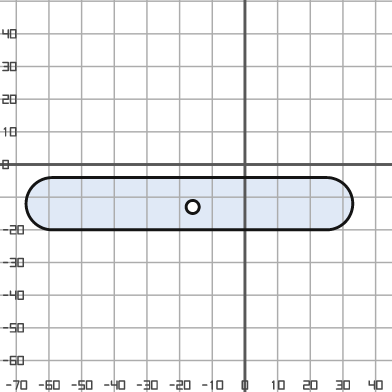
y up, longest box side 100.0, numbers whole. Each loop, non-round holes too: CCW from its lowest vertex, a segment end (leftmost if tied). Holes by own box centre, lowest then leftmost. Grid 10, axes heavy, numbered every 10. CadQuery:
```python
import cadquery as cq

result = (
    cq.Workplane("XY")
    .moveTo(-59.0, -20.0)
    .lineTo(25.0, -20.0)
    .threePointArc((33.0, -12.0), (25.0, -4.0))
    .lineTo(-59.0, -4.0)
    .threePointArc((-67.0, -12.0), (-59.0, -20.0))
    .close()
    .moveTo(-16.0, -13.0)
    .circle(2.0)
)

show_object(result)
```